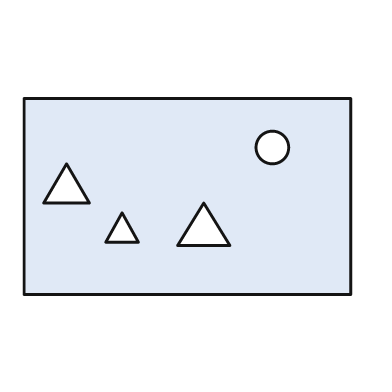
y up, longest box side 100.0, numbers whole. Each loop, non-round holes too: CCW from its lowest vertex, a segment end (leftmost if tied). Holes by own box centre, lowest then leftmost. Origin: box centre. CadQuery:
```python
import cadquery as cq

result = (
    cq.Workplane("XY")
    .moveTo(-50.0, -30.0)
    .lineTo(50.0, -30.0)
    .lineTo(50.0, 30.0)
    .lineTo(-50.0, 30.0)
    .close()
    .moveTo(-25.0, -14.0)
    .lineTo(-15.0, -14.0)
    .lineTo(-20.0, -5.0)
    .close()
    .moveTo(-3.0, -15.0)
    .lineTo(13.0, -15.0)
    .lineTo(5.0, -2.0)
    .close()
    .moveTo(-44.0, -2.0)
    .lineTo(-30.0, -2.0)
    .lineTo(-37.0, 10.0)
    .close()
    .moveTo(26.0, 15.0)
    .circle(5.0)
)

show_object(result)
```